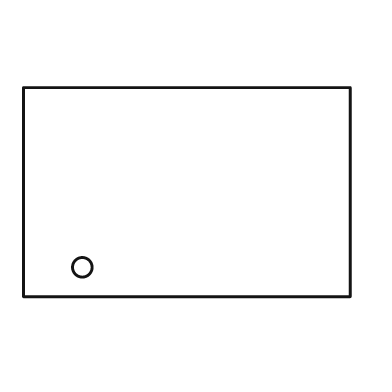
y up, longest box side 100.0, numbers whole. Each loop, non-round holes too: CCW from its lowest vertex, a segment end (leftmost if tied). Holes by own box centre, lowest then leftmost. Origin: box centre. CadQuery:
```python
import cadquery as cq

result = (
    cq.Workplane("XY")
    .moveTo(-50.0, -32.0)
    .lineTo(50.0, -32.0)
    .lineTo(50.0, 32.0)
    .lineTo(-50.0, 32.0)
    .close()
    .moveTo(-32.0, -23.0)
    .circle(3.0)
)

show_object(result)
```